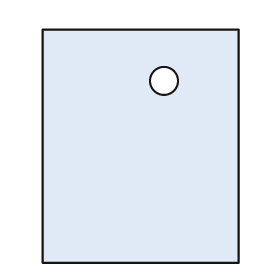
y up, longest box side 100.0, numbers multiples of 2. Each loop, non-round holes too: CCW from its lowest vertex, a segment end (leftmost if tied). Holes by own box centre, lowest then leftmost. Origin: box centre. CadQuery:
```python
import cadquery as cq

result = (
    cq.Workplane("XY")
    .moveTo(-42.0, -50.0)
    .lineTo(42.0, -50.0)
    .lineTo(42.0, 50.0)
    .lineTo(-42.0, 50.0)
    .close()
    .moveTo(10.0, 28.0)
    .circle(6.0)
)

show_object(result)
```